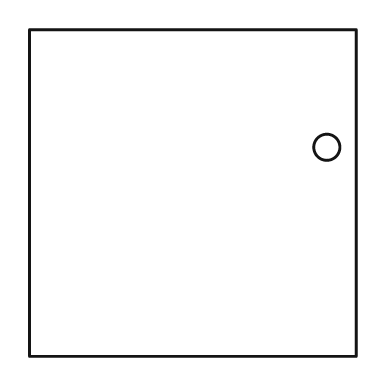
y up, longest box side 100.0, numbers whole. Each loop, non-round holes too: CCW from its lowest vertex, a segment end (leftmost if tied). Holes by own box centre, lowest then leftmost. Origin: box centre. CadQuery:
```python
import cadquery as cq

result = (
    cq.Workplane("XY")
    .moveTo(-50.0, -50.0)
    .lineTo(50.0, -50.0)
    .lineTo(50.0, 50.0)
    .lineTo(-50.0, 50.0)
    .close()
    .moveTo(41.0, 14.0)
    .circle(4.0)
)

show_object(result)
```